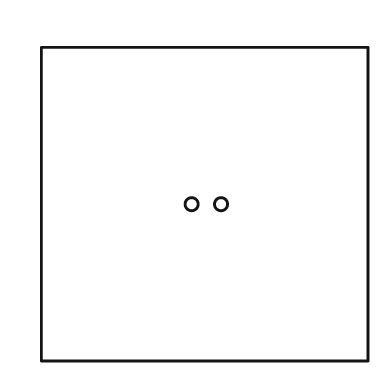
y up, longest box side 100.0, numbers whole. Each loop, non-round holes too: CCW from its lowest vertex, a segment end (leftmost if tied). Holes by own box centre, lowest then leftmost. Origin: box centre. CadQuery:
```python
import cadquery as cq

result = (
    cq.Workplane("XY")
    .moveTo(-50.0, -48.0)
    .lineTo(50.0, -48.0)
    .lineTo(50.0, 48.0)
    .lineTo(-50.0, 48.0)
    .close()
    .moveTo(-4.0, 0.0)
    .circle(2.0)
    .moveTo(5.0, 0.0)
    .circle(2.0)
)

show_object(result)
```